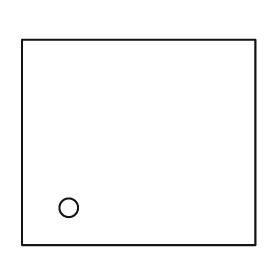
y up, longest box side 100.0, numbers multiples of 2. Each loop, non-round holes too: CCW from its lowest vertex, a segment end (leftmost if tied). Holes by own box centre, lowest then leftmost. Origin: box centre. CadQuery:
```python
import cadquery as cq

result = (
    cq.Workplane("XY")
    .moveTo(-50.0, -44.0)
    .lineTo(50.0, -44.0)
    .lineTo(50.0, 44.0)
    .lineTo(-50.0, 44.0)
    .close()
    .moveTo(-30.0, -28.0)
    .circle(4.0)
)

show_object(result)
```